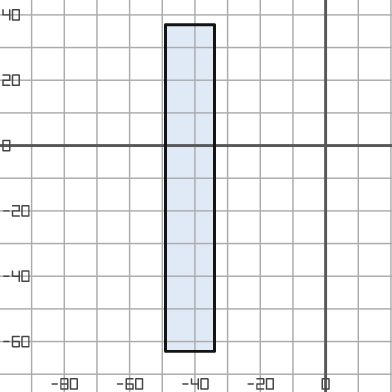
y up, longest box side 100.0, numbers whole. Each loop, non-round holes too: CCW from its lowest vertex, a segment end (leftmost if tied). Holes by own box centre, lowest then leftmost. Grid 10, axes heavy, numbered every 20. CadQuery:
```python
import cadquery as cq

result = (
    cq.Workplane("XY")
    .moveTo(-49.0, -63.0)
    .lineTo(-34.0, -63.0)
    .lineTo(-34.0, 37.0)
    .lineTo(-49.0, 37.0)
    .close()
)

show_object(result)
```